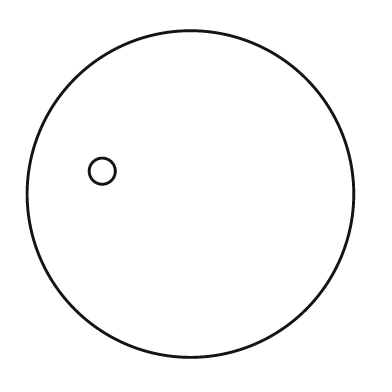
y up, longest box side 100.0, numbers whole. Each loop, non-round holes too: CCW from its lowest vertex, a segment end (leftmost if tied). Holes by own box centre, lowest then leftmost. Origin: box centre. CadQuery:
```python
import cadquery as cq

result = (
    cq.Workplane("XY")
    .moveTo(0.0, 0.0)
    .circle(50.0)
    .moveTo(-27.0, 7.0)
    .circle(4.0)
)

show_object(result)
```